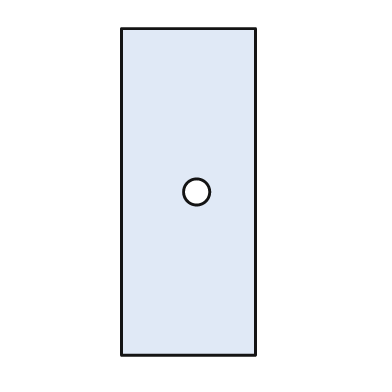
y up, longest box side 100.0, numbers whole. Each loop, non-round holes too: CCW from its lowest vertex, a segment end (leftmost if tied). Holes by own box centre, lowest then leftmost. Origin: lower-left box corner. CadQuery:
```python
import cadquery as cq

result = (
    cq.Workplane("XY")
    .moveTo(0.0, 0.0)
    .lineTo(41.0, 0.0)
    .lineTo(41.0, 100.0)
    .lineTo(0.0, 100.0)
    .close()
    .moveTo(23.0, 50.0)
    .circle(4.0)
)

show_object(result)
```